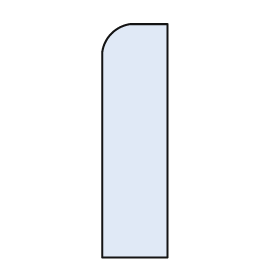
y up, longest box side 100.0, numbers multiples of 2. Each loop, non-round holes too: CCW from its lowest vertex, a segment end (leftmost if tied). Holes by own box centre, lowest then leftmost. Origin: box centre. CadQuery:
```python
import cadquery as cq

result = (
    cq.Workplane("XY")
    .moveTo(-14.0, -50.0)
    .lineTo(14.0, -50.0)
    .lineTo(14.0, 50.0)
    .lineTo(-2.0, 50.0)
    .threePointArc((-10.0, 46.0), (-14.0, 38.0))
    .close()
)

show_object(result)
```